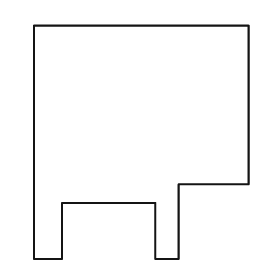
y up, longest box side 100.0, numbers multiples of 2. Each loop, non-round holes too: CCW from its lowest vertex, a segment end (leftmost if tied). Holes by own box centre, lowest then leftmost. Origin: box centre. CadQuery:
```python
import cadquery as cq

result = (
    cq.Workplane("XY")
    .moveTo(-46.0, -50.0)
    .lineTo(-34.0, -50.0)
    .lineTo(-34.0, -26.0)
    .lineTo(6.0, -26.0)
    .lineTo(6.0, -50.0)
    .lineTo(16.0, -50.0)
    .lineTo(16.0, -18.0)
    .lineTo(46.0, -18.0)
    .lineTo(46.0, 50.0)
    .lineTo(-46.0, 50.0)
    .close()
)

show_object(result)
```